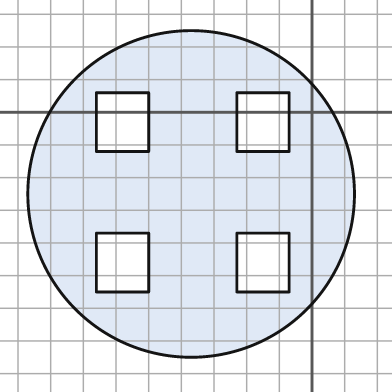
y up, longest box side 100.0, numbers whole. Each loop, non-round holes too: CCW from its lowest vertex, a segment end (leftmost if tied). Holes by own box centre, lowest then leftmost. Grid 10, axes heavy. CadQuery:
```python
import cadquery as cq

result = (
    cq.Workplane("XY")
    .moveTo(-37.0, -25.0)
    .circle(50.0)
    .moveTo(-66.0, -55.0)
    .lineTo(-50.0, -55.0)
    .lineTo(-50.0, -37.0)
    .lineTo(-66.0, -37.0)
    .close()
    .moveTo(-23.0, -55.0)
    .lineTo(-7.0, -55.0)
    .lineTo(-7.0, -37.0)
    .lineTo(-23.0, -37.0)
    .close()
    .moveTo(-66.0, -12.0)
    .lineTo(-50.0, -12.0)
    .lineTo(-50.0, 6.0)
    .lineTo(-66.0, 6.0)
    .close()
    .moveTo(-23.0, -12.0)
    .lineTo(-7.0, -12.0)
    .lineTo(-7.0, 6.0)
    .lineTo(-23.0, 6.0)
    .close()
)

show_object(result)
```